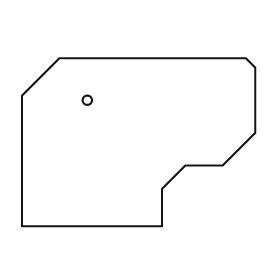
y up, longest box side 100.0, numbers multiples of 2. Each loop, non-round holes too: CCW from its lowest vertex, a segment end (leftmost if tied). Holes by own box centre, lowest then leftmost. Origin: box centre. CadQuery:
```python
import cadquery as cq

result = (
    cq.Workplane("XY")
    .moveTo(-50.0, -36.0)
    .lineTo(10.0, -36.0)
    .lineTo(10.0, -20.0)
    .lineTo(20.0, -10.0)
    .lineTo(36.0, -10.0)
    .lineTo(50.0, 4.0)
    .lineTo(50.0, 32.0)
    .lineTo(46.0, 36.0)
    .lineTo(-34.0, 36.0)
    .lineTo(-50.0, 20.0)
    .close()
    .moveTo(-22.0, 18.0)
    .circle(2.0)
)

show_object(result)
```